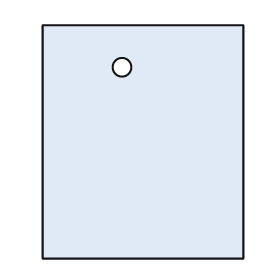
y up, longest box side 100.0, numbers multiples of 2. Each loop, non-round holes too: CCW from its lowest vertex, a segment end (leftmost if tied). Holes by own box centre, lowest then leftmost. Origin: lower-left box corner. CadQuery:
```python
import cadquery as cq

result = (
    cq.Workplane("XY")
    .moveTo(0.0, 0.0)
    .lineTo(86.0, 0.0)
    .lineTo(86.0, 100.0)
    .lineTo(0.0, 100.0)
    .close()
    .moveTo(34.0, 82.0)
    .circle(4.0)
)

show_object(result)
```